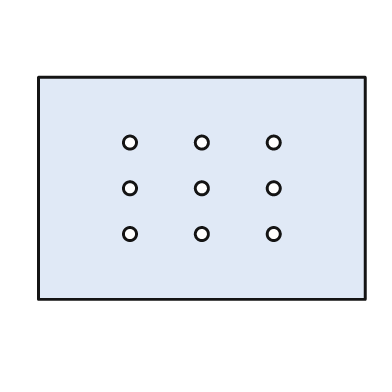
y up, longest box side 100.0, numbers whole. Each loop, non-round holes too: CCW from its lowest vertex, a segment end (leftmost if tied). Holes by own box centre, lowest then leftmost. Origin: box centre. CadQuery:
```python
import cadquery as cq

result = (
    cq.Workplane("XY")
    .moveTo(-50.0, -34.0)
    .lineTo(50.0, -34.0)
    .lineTo(50.0, 34.0)
    .lineTo(-50.0, 34.0)
    .close()
    .moveTo(-22.0, -14.0)
    .circle(2.0)
    .moveTo(0.0, -14.0)
    .circle(2.0)
    .moveTo(22.0, -14.0)
    .circle(2.0)
    .moveTo(-22.0, 0.0)
    .circle(2.0)
    .moveTo(0.0, 0.0)
    .circle(2.0)
    .moveTo(22.0, 0.0)
    .circle(2.0)
    .moveTo(-22.0, 14.0)
    .circle(2.0)
    .moveTo(0.0, 14.0)
    .circle(2.0)
    .moveTo(22.0, 14.0)
    .circle(2.0)
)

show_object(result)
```